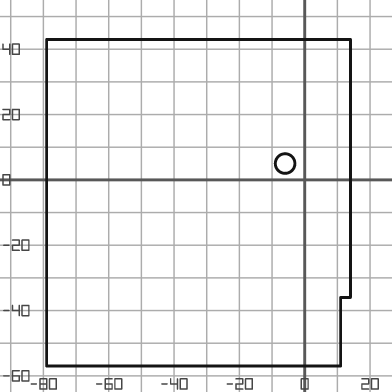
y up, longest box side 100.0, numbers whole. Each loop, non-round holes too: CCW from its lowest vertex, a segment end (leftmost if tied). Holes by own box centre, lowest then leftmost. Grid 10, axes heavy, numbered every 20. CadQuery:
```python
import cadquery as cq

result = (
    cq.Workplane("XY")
    .moveTo(-79.0, -57.0)
    .lineTo(11.0, -57.0)
    .lineTo(11.0, -36.0)
    .lineTo(14.0, -36.0)
    .lineTo(14.0, 43.0)
    .lineTo(-79.0, 43.0)
    .close()
    .moveTo(-6.0, 5.0)
    .circle(3.0)
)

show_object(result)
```